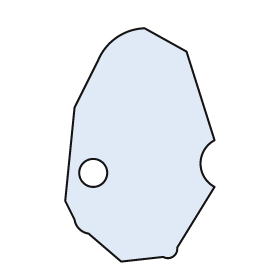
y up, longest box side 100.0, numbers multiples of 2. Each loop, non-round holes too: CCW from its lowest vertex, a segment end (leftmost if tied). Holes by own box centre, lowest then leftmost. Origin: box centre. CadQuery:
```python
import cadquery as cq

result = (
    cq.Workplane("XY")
    .moveTo(-8.0, -50.0)
    .lineTo(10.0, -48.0)
    .threePointArc((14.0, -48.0), (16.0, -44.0))
    .lineTo(32.0, -18.0)
    .threePointArc((26.0, -8.0), (32.0, 2.0))
    .lineTo(20.0, 40.0)
    .lineTo(2.0, 50.0)
    .threePointArc((-10.0, 46.0), (-18.0, 36.0))
    .lineTo(-28.0, 16.0)
    .lineTo(-32.0, -24.0)
    .lineTo(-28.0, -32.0)
    .threePointArc((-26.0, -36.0), (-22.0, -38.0))
    .close()
    .moveTo(-20.0, -12.0)
    .circle(6.0)
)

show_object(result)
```